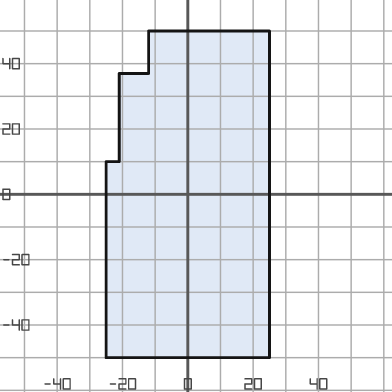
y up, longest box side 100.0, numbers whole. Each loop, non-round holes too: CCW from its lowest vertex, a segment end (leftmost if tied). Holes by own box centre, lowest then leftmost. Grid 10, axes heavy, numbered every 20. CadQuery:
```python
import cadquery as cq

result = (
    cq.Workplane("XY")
    .moveTo(-25.0, -50.0)
    .lineTo(25.0, -50.0)
    .lineTo(25.0, 50.0)
    .lineTo(-12.0, 50.0)
    .lineTo(-12.0, 37.0)
    .lineTo(-21.0, 37.0)
    .lineTo(-21.0, 10.0)
    .lineTo(-25.0, 10.0)
    .close()
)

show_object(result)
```